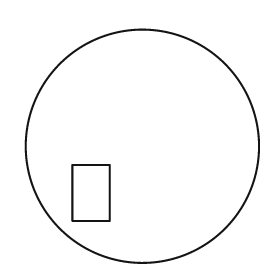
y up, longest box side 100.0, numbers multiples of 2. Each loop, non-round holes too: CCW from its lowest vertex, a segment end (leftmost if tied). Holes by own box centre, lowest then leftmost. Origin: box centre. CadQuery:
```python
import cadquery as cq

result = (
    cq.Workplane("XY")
    .moveTo(0.0, 0.0)
    .circle(50.0)
    .moveTo(-30.0, -32.0)
    .lineTo(-14.0, -32.0)
    .lineTo(-14.0, -8.0)
    .lineTo(-30.0, -8.0)
    .close()
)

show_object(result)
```